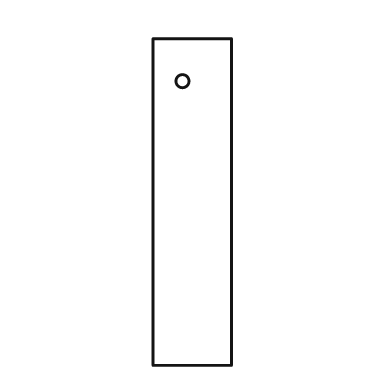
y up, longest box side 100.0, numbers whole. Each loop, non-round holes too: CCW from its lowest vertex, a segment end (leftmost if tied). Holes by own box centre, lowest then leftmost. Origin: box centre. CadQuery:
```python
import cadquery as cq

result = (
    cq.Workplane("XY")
    .moveTo(-12.0, -50.0)
    .lineTo(12.0, -50.0)
    .lineTo(12.0, 50.0)
    .lineTo(-12.0, 50.0)
    .close()
    .moveTo(-3.0, 37.0)
    .circle(2.0)
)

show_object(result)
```